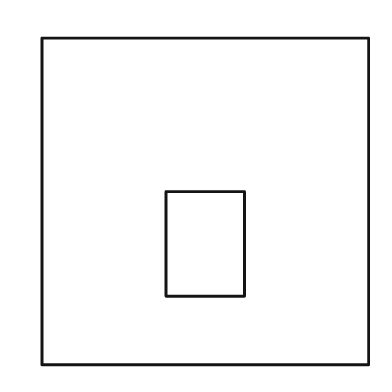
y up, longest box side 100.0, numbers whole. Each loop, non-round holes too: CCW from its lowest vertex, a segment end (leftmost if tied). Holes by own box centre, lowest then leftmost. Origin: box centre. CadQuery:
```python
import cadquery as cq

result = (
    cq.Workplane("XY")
    .moveTo(-50.0, -50.0)
    .lineTo(50.0, -50.0)
    .lineTo(50.0, 50.0)
    .lineTo(-50.0, 50.0)
    .close()
    .moveTo(-12.0, -29.0)
    .lineTo(12.0, -29.0)
    .lineTo(12.0, 3.0)
    .lineTo(-12.0, 3.0)
    .close()
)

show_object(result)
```